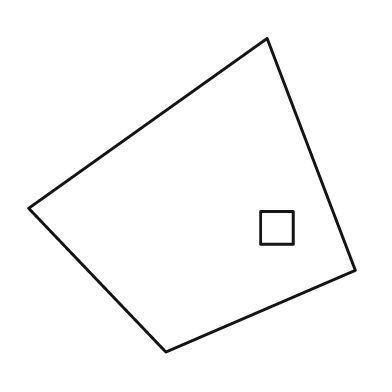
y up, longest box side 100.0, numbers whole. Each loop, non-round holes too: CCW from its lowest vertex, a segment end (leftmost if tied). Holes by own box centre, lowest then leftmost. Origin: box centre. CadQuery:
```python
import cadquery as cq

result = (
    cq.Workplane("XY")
    .moveTo(-8.0, -48.0)
    .lineTo(50.0, -23.0)
    .lineTo(23.0, 48.0)
    .lineTo(-50.0, -4.0)
    .close()
    .moveTo(21.0, -15.0)
    .lineTo(31.0, -15.0)
    .lineTo(31.0, -5.0)
    .lineTo(21.0, -5.0)
    .close()
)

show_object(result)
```